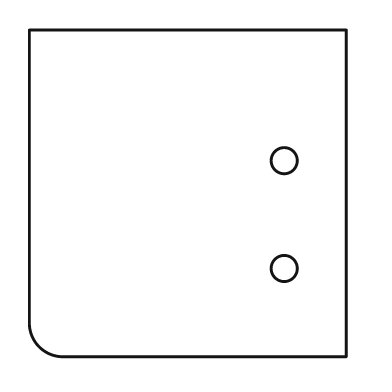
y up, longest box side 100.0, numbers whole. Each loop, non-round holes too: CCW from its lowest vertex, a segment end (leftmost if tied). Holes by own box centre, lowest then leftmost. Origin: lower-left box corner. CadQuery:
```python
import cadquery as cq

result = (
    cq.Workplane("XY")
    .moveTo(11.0, 0.0)
    .lineTo(97.0, 0.0)
    .lineTo(97.0, 100.0)
    .lineTo(0.0, 100.0)
    .lineTo(0.0, 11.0)
    .threePointArc((3.0, 3.0), (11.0, 0.0))
    .close()
    .moveTo(78.0, 27.0)
    .circle(4.0)
    .moveTo(78.0, 60.0)
    .circle(4.0)
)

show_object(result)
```